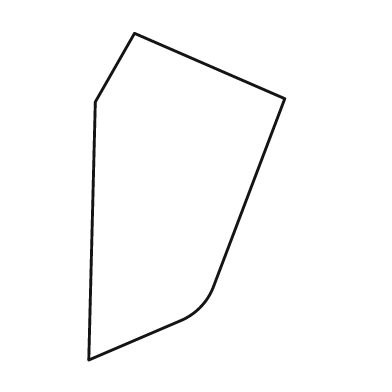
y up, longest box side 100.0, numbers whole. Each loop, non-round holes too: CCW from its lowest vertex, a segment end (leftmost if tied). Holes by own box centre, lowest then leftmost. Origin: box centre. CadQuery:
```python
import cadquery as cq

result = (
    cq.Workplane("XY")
    .moveTo(-30.0, -50.0)
    .lineTo(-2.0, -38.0)
    .threePointArc((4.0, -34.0), (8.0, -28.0))
    .lineTo(30.0, 30.0)
    .lineTo(-16.0, 50.0)
    .lineTo(-28.0, 29.0)
    .close()
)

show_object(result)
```